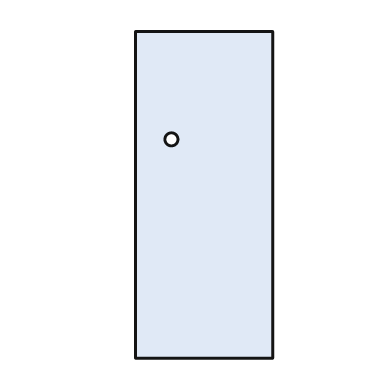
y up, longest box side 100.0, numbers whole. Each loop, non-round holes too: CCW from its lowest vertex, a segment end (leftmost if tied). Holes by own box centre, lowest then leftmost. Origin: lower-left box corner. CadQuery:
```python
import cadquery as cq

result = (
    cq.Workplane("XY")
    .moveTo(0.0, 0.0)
    .lineTo(42.0, 0.0)
    .lineTo(42.0, 100.0)
    .lineTo(0.0, 100.0)
    .close()
    .moveTo(11.0, 67.0)
    .circle(2.0)
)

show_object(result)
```